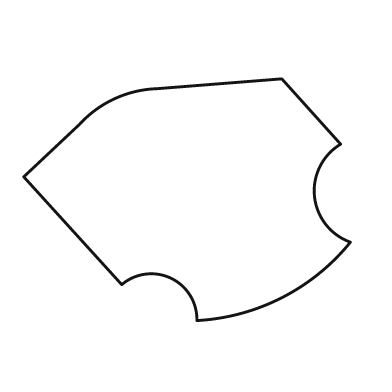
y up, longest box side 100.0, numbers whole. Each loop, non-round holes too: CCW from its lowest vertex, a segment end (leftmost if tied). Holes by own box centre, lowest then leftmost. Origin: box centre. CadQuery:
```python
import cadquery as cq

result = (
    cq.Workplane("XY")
    .moveTo(3.0, -37.0)
    .threePointArc((29.0, -30.0), (50.0, -13.0))
    .threePointArc((39.0, 1.0), (47.0, 17.0))
    .lineTo(29.0, 37.0)
    .lineTo(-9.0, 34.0)
    .threePointArc((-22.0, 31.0), (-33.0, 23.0))
    .lineTo(-50.0, 7.0)
    .lineTo(-20.0, -26.0)
    .threePointArc((-5.0, -24.0), (3.0, -37.0))
    .close()
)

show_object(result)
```